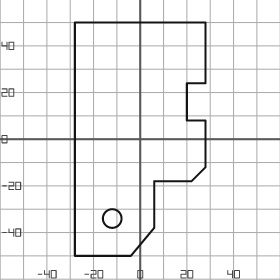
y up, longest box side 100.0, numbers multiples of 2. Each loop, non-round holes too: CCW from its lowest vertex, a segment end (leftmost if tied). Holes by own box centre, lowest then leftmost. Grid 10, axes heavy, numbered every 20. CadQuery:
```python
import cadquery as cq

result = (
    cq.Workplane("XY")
    .moveTo(-28.0, -50.0)
    .lineTo(-4.0, -50.0)
    .lineTo(6.0, -38.0)
    .lineTo(6.0, -18.0)
    .lineTo(22.0, -18.0)
    .lineTo(28.0, -12.0)
    .lineTo(28.0, 8.0)
    .lineTo(20.0, 8.0)
    .lineTo(20.0, 24.0)
    .lineTo(28.0, 24.0)
    .lineTo(28.0, 50.0)
    .lineTo(-28.0, 50.0)
    .close()
    .moveTo(-12.0, -34.0)
    .circle(4.0)
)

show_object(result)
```